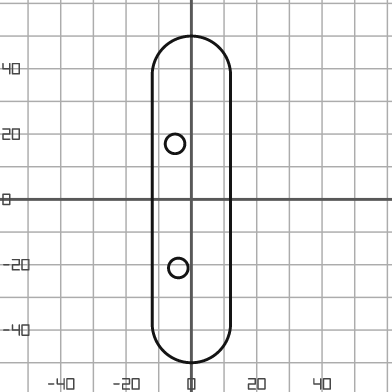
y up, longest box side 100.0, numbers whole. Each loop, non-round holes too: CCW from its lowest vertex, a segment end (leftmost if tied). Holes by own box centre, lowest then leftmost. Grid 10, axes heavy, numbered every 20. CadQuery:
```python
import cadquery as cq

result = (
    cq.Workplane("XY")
    .moveTo(-12.0, -38.0)
    .threePointArc((0.0, -50.0), (12.0, -38.0))
    .lineTo(12.0, 38.0)
    .threePointArc((0.0, 50.0), (-12.0, 38.0))
    .close()
    .moveTo(-4.0, -21.0)
    .circle(3.0)
    .moveTo(-5.0, 17.0)
    .circle(3.0)
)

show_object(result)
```